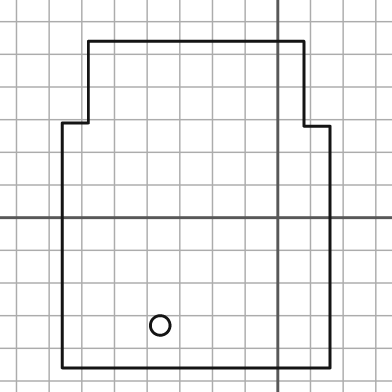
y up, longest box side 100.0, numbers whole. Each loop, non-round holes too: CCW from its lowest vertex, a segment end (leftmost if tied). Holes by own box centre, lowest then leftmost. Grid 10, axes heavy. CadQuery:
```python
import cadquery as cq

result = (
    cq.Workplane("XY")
    .moveTo(-66.0, -46.0)
    .lineTo(16.0, -46.0)
    .lineTo(16.0, 28.0)
    .lineTo(8.0, 28.0)
    .lineTo(8.0, 54.0)
    .lineTo(-58.0, 54.0)
    .lineTo(-58.0, 29.0)
    .lineTo(-66.0, 29.0)
    .close()
    .moveTo(-36.0, -33.0)
    .circle(3.0)
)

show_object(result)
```